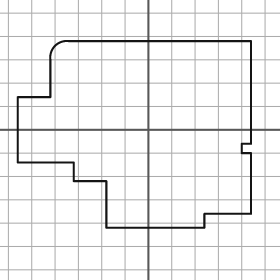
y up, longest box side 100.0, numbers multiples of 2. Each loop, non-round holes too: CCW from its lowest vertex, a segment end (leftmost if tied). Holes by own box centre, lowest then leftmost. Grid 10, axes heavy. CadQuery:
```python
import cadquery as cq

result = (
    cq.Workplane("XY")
    .moveTo(-18.0, -42.0)
    .lineTo(24.0, -42.0)
    .lineTo(24.0, -36.0)
    .lineTo(44.0, -36.0)
    .lineTo(44.0, -10.0)
    .lineTo(40.0, -10.0)
    .lineTo(40.0, -6.0)
    .lineTo(44.0, -6.0)
    .lineTo(44.0, 38.0)
    .lineTo(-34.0, 38.0)
    .threePointArc((-40.0, 36.0), (-42.0, 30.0))
    .lineTo(-42.0, 14.0)
    .lineTo(-56.0, 14.0)
    .lineTo(-56.0, -14.0)
    .lineTo(-32.0, -14.0)
    .lineTo(-32.0, -22.0)
    .lineTo(-18.0, -22.0)
    .close()
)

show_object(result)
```